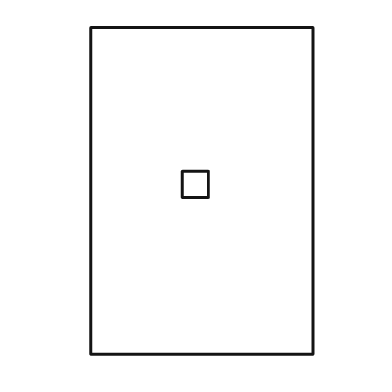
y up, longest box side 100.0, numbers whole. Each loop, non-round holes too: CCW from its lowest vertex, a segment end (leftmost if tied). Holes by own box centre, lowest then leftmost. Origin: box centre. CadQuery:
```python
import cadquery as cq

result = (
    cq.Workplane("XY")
    .moveTo(-34.0, -50.0)
    .lineTo(34.0, -50.0)
    .lineTo(34.0, 50.0)
    .lineTo(-34.0, 50.0)
    .close()
    .moveTo(-6.0, -2.0)
    .lineTo(2.0, -2.0)
    .lineTo(2.0, 6.0)
    .lineTo(-6.0, 6.0)
    .close()
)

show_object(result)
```